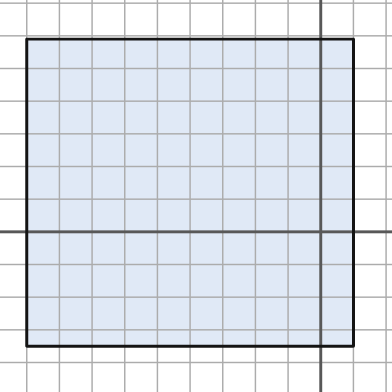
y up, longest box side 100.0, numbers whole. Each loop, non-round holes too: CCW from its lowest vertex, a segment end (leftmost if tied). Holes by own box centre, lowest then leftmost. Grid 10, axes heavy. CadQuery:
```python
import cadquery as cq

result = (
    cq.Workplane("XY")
    .moveTo(-90.0, -35.0)
    .lineTo(10.0, -35.0)
    .lineTo(10.0, 59.0)
    .lineTo(-90.0, 59.0)
    .close()
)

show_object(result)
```